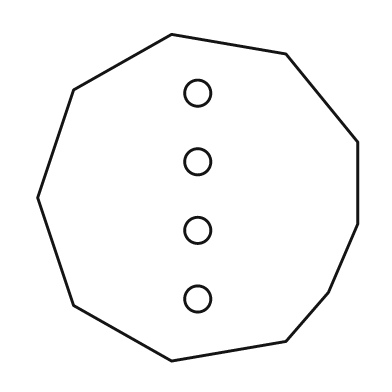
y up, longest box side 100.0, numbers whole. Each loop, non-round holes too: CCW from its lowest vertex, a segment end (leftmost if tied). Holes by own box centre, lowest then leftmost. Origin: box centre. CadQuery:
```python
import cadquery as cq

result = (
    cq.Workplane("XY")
    .moveTo(-8.0, -50.0)
    .lineTo(27.0, -44.0)
    .lineTo(40.0, -29.0)
    .lineTo(49.0, -8.0)
    .lineTo(49.0, 17.0)
    .lineTo(27.0, 44.0)
    .lineTo(-8.0, 50.0)
    .lineTo(-38.0, 33.0)
    .lineTo(-49.0, 0.0)
    .lineTo(-38.0, -33.0)
    .close()
    .moveTo(0.0, -31.0)
    .circle(4.0)
    .moveTo(0.0, -10.0)
    .circle(4.0)
    .moveTo(0.0, 11.0)
    .circle(4.0)
    .moveTo(0.0, 32.0)
    .circle(4.0)
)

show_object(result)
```